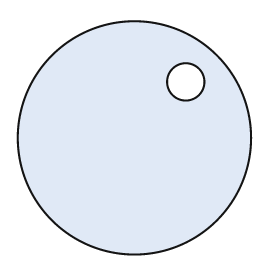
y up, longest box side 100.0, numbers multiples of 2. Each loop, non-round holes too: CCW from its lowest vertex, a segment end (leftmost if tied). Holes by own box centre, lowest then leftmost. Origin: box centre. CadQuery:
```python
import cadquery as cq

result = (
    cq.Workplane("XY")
    .moveTo(0.0, 0.0)
    .circle(50.0)
    .moveTo(22.0, 24.0)
    .circle(8.0)
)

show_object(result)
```